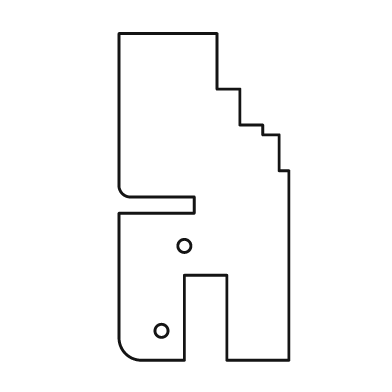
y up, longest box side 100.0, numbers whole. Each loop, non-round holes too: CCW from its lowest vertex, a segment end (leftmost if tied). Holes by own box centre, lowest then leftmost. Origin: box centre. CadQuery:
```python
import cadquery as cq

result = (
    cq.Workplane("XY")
    .moveTo(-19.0, -50.0)
    .lineTo(-6.0, -50.0)
    .lineTo(-6.0, -24.0)
    .lineTo(7.0, -24.0)
    .lineTo(7.0, -50.0)
    .lineTo(26.0, -50.0)
    .lineTo(26.0, 8.0)
    .lineTo(23.0, 8.0)
    .lineTo(23.0, 19.0)
    .lineTo(18.0, 19.0)
    .lineTo(18.0, 22.0)
    .lineTo(11.0, 22.0)
    .lineTo(11.0, 33.0)
    .lineTo(4.0, 33.0)
    .lineTo(4.0, 50.0)
    .lineTo(-26.0, 50.0)
    .lineTo(-26.0, 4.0)
    .threePointArc((-25.0, 1.0), (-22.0, 0.0))
    .lineTo(-3.0, 0.0)
    .lineTo(-3.0, -5.0)
    .lineTo(-26.0, -5.0)
    .lineTo(-26.0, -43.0)
    .threePointArc((-24.0, -48.0), (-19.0, -50.0))
    .close()
    .moveTo(-13.0, -41.0)
    .circle(2.0)
    .moveTo(-6.0, -15.0)
    .circle(2.0)
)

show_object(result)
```